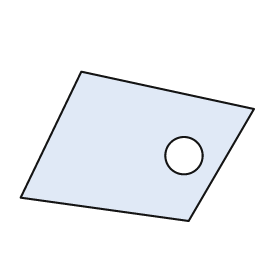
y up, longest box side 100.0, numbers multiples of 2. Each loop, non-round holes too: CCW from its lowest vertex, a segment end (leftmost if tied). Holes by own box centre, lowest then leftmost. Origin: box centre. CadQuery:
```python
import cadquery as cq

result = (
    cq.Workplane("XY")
    .moveTo(22.0, -32.0)
    .lineTo(50.0, 16.0)
    .lineTo(-24.0, 32.0)
    .lineTo(-50.0, -22.0)
    .close()
    .moveTo(20.0, -4.0)
    .circle(8.0)
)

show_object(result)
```